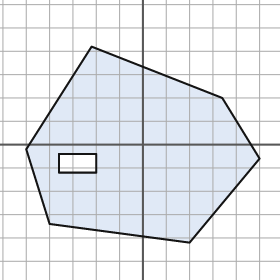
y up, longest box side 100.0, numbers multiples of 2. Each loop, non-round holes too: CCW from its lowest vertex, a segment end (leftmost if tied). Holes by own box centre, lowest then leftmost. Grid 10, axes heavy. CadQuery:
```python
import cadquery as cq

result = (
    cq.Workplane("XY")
    .moveTo(20.0, -42.0)
    .lineTo(50.0, -6.0)
    .lineTo(34.0, 20.0)
    .lineTo(-22.0, 42.0)
    .lineTo(-50.0, -2.0)
    .lineTo(-40.0, -34.0)
    .close()
    .moveTo(-36.0, -12.0)
    .lineTo(-20.0, -12.0)
    .lineTo(-20.0, -4.0)
    .lineTo(-36.0, -4.0)
    .close()
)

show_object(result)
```